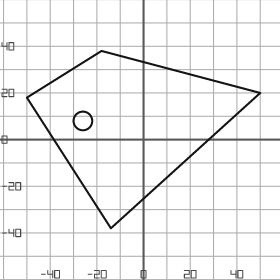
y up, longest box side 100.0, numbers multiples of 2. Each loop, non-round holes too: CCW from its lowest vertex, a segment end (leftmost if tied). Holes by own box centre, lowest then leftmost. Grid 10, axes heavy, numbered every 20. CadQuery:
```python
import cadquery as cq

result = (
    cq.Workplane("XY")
    .moveTo(-14.0, -38.0)
    .lineTo(50.0, 20.0)
    .lineTo(-18.0, 38.0)
    .lineTo(-50.0, 18.0)
    .close()
    .moveTo(-26.0, 8.0)
    .circle(4.0)
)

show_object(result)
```